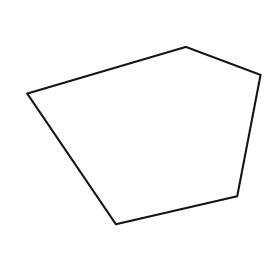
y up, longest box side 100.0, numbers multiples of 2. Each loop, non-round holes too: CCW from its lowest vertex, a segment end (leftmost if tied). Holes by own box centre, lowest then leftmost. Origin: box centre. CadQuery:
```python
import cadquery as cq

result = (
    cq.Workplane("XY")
    .moveTo(-12.0, -38.0)
    .lineTo(40.0, -26.0)
    .lineTo(50.0, 26.0)
    .lineTo(18.0, 38.0)
    .lineTo(-50.0, 18.0)
    .close()
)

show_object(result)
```